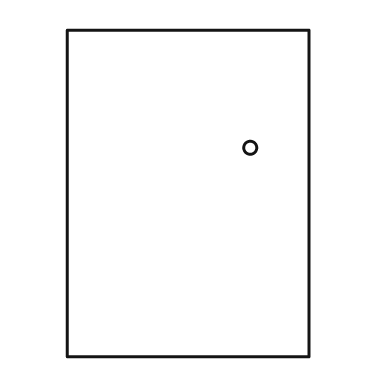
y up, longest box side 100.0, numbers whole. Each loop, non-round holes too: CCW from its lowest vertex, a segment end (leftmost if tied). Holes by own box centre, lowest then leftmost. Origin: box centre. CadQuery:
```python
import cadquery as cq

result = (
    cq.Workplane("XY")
    .moveTo(-37.0, -50.0)
    .lineTo(37.0, -50.0)
    .lineTo(37.0, 50.0)
    .lineTo(-37.0, 50.0)
    .close()
    .moveTo(19.0, 14.0)
    .circle(2.0)
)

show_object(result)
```